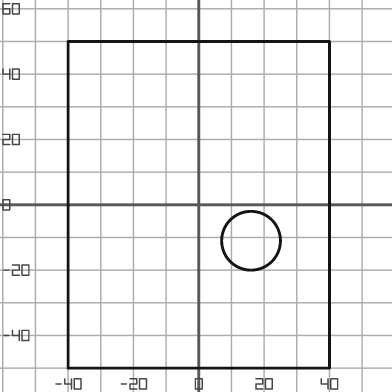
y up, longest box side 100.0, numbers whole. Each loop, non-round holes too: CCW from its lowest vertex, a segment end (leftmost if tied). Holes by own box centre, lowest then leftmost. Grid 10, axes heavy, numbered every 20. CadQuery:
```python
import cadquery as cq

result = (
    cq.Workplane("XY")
    .moveTo(-40.0, -50.0)
    .lineTo(40.0, -50.0)
    .lineTo(40.0, 50.0)
    .lineTo(-40.0, 50.0)
    .close()
    .moveTo(16.0, -11.0)
    .circle(9.0)
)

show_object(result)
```